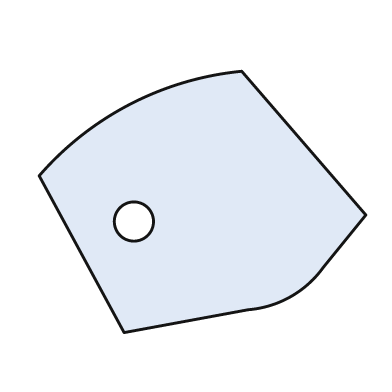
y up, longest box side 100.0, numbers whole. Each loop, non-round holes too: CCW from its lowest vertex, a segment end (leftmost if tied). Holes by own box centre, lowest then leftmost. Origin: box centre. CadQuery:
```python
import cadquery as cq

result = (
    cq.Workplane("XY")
    .moveTo(-24.0, -40.0)
    .lineTo(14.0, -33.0)
    .threePointArc((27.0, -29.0), (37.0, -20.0))
    .lineTo(50.0, -4.0)
    .lineTo(12.0, 40.0)
    .threePointArc((-22.0, 30.0), (-50.0, 8.0))
    .close()
    .moveTo(-21.0, -6.0)
    .circle(6.0)
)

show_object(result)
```